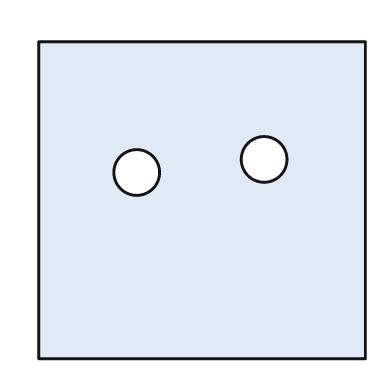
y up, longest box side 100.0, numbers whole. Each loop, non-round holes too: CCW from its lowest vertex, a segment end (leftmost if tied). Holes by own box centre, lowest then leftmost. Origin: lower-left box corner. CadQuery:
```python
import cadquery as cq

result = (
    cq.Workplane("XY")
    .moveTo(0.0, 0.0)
    .lineTo(100.0, 0.0)
    .lineTo(100.0, 97.0)
    .lineTo(0.0, 97.0)
    .close()
    .moveTo(30.0, 57.0)
    .circle(7.0)
    .moveTo(69.0, 61.0)
    .circle(7.0)
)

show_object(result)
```